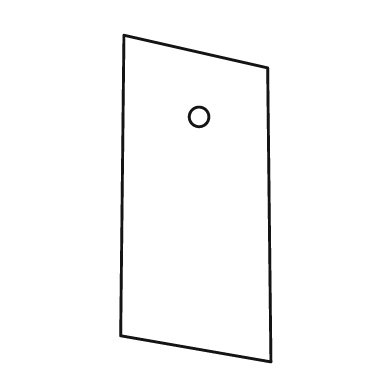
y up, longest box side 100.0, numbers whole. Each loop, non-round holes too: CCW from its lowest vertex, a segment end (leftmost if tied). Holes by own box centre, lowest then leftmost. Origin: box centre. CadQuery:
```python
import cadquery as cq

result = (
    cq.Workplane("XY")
    .moveTo(23.0, -50.0)
    .lineTo(22.0, 40.0)
    .lineTo(-22.0, 50.0)
    .lineTo(-23.0, -42.0)
    .close()
    .moveTo(1.0, 25.0)
    .circle(3.0)
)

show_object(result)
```